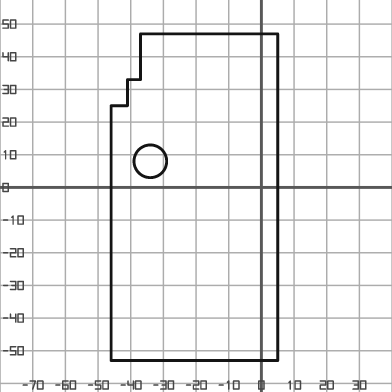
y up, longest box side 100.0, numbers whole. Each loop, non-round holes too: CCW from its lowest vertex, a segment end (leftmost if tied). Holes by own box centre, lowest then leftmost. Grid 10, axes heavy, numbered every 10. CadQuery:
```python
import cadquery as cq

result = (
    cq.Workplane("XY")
    .moveTo(-46.0, -53.0)
    .lineTo(5.0, -53.0)
    .lineTo(5.0, 47.0)
    .lineTo(-37.0, 47.0)
    .lineTo(-37.0, 33.0)
    .lineTo(-41.0, 33.0)
    .lineTo(-41.0, 25.0)
    .lineTo(-46.0, 25.0)
    .close()
    .moveTo(-34.0, 8.0)
    .circle(5.0)
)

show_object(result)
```